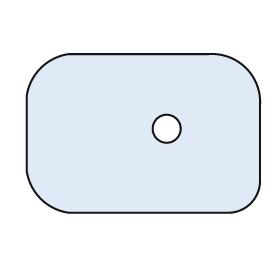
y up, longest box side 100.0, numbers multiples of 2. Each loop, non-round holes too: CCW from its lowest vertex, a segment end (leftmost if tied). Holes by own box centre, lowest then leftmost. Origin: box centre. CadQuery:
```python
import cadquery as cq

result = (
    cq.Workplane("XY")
    .moveTo(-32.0, -34.0)
    .lineTo(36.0, -34.0)
    .threePointArc((46.0, -30.0), (50.0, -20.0))
    .lineTo(50.0, 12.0)
    .threePointArc((44.0, 28.0), (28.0, 34.0))
    .lineTo(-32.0, 34.0)
    .threePointArc((-44.0, 28.0), (-50.0, 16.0))
    .lineTo(-50.0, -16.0)
    .threePointArc((-44.0, -28.0), (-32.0, -34.0))
    .close()
    .moveTo(10.0, 2.0)
    .circle(6.0)
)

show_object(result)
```